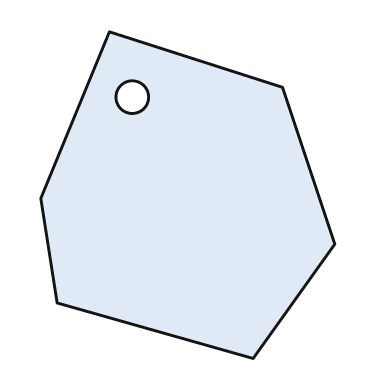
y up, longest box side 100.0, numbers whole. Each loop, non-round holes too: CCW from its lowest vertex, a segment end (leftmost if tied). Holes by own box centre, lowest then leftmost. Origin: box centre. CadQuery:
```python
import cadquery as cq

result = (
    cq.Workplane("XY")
    .moveTo(20.0, -50.0)
    .lineTo(45.0, -15.0)
    .lineTo(29.0, 33.0)
    .lineTo(-24.0, 50.0)
    .lineTo(-45.0, -1.0)
    .lineTo(-40.0, -33.0)
    .close()
    .moveTo(-17.0, 30.0)
    .circle(5.0)
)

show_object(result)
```